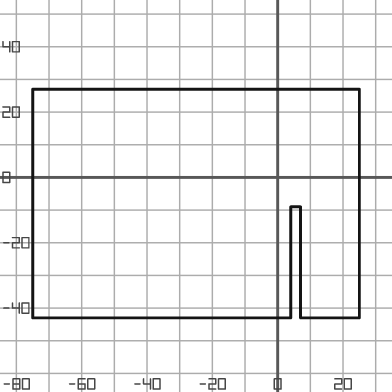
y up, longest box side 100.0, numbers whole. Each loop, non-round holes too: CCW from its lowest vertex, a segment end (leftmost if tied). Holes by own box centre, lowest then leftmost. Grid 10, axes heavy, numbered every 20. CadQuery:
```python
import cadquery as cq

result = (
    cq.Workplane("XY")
    .moveTo(-75.0, -43.0)
    .lineTo(4.0, -43.0)
    .lineTo(4.0, -9.0)
    .lineTo(7.0, -9.0)
    .lineTo(7.0, -43.0)
    .lineTo(25.0, -43.0)
    .lineTo(25.0, 27.0)
    .lineTo(-75.0, 27.0)
    .close()
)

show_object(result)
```